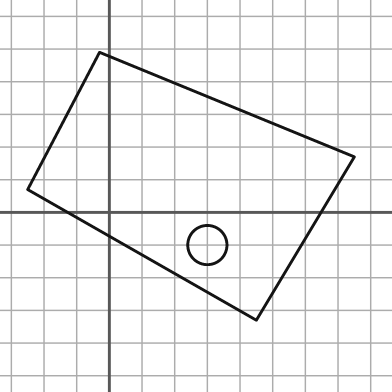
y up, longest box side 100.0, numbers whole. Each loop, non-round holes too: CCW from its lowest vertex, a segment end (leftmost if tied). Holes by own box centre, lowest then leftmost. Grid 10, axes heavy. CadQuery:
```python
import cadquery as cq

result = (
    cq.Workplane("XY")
    .moveTo(45.0, -33.0)
    .lineTo(75.0, 17.0)
    .lineTo(-3.0, 49.0)
    .lineTo(-25.0, 7.0)
    .close()
    .moveTo(30.0, -10.0)
    .circle(6.0)
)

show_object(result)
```